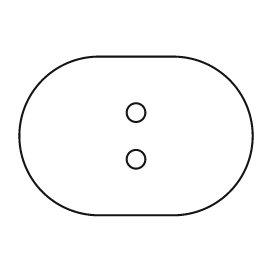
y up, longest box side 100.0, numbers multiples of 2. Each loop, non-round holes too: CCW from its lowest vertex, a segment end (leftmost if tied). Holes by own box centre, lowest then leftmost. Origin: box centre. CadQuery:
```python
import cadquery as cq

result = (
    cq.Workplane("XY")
    .moveTo(-16.0, -34.0)
    .lineTo(16.0, -34.0)
    .threePointArc((50.0, 0.0), (16.0, 34.0))
    .lineTo(-16.0, 34.0)
    .threePointArc((-50.0, 0.0), (-16.0, -34.0))
    .close()
    .moveTo(0.0, -10.0)
    .circle(4.0)
    .moveTo(0.0, 10.0)
    .circle(4.0)
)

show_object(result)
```